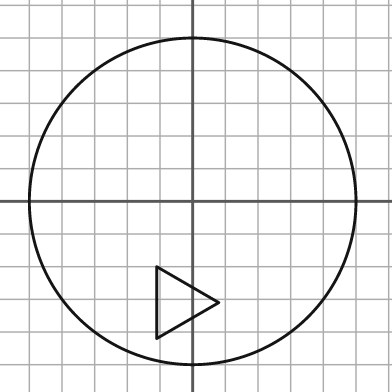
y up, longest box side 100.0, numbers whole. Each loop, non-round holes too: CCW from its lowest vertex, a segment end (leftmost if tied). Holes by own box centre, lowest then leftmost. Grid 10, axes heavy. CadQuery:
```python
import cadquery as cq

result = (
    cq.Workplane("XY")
    .moveTo(0.0, 0.0)
    .circle(50.0)
    .moveTo(-11.0, -42.0)
    .lineTo(8.0, -31.0)
    .lineTo(-11.0, -20.0)
    .close()
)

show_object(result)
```